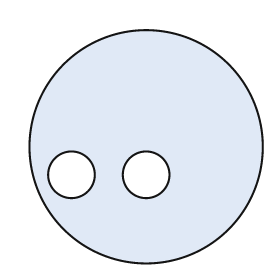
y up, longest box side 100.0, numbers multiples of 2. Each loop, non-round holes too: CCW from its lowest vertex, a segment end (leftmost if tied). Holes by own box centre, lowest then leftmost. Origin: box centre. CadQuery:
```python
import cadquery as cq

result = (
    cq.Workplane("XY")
    .moveTo(0.0, 0.0)
    .circle(50.0)
    .moveTo(-32.0, -12.0)
    .circle(10.0)
    .moveTo(0.0, -12.0)
    .circle(10.0)
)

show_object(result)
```